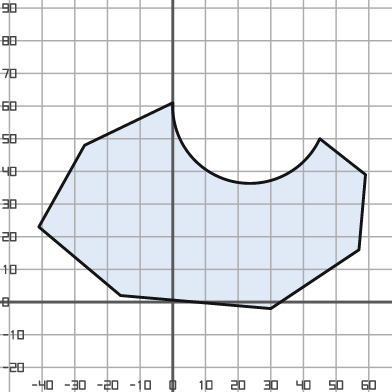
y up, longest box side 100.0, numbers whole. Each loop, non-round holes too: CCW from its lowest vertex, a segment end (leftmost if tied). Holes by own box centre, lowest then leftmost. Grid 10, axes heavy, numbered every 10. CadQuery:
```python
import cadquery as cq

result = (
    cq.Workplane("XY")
    .moveTo(30.0, -2.0)
    .lineTo(57.0, 16.0)
    .lineTo(59.0, 39.0)
    .lineTo(45.0, 50.0)
    .threePointArc((18.0, 37.0), (0.0, 61.0))
    .lineTo(-27.0, 48.0)
    .lineTo(-41.0, 23.0)
    .lineTo(-16.0, 2.0)
    .close()
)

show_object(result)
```